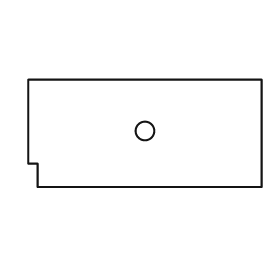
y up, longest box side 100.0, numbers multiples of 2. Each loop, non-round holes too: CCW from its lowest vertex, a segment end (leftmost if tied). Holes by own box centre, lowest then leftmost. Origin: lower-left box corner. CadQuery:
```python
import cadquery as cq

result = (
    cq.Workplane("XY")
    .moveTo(4.0, 0.0)
    .lineTo(100.0, 0.0)
    .lineTo(100.0, 46.0)
    .lineTo(0.0, 46.0)
    .lineTo(0.0, 10.0)
    .lineTo(4.0, 10.0)
    .close()
    .moveTo(50.0, 24.0)
    .circle(4.0)
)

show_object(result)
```